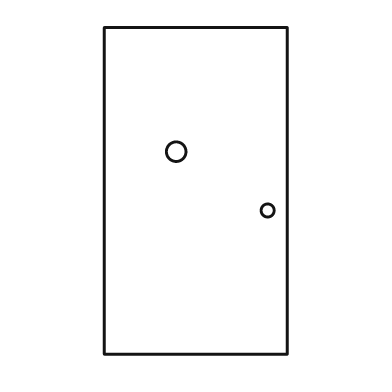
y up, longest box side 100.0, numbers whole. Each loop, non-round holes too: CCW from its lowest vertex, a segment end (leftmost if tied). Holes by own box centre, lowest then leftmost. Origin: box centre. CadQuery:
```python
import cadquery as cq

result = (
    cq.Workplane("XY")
    .moveTo(-28.0, -50.0)
    .lineTo(28.0, -50.0)
    .lineTo(28.0, 50.0)
    .lineTo(-28.0, 50.0)
    .close()
    .moveTo(22.0, -6.0)
    .circle(2.0)
    .moveTo(-6.0, 12.0)
    .circle(3.0)
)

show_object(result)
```